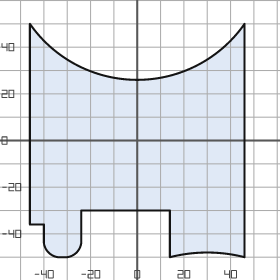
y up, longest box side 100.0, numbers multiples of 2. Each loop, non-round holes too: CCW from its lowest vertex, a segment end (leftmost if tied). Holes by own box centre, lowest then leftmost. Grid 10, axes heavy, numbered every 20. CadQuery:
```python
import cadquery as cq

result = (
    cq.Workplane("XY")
    .moveTo(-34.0, -50.0)
    .lineTo(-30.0, -50.0)
    .threePointArc((-26.0, -48.0), (-24.0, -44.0))
    .lineTo(-24.0, -30.0)
    .lineTo(14.0, -30.0)
    .lineTo(14.0, -50.0)
    .threePointArc((30.0, -48.0), (46.0, -50.0))
    .lineTo(46.0, 50.0)
    .threePointArc((0.0, 26.0), (-46.0, 50.0))
    .lineTo(-46.0, -36.0)
    .lineTo(-40.0, -36.0)
    .lineTo(-40.0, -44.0)
    .threePointArc((-38.0, -48.0), (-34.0, -50.0))
    .close()
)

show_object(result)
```